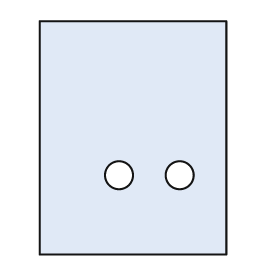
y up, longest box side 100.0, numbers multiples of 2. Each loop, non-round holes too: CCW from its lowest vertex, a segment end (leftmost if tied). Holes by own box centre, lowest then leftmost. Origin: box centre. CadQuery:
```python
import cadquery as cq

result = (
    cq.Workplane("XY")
    .moveTo(-40.0, -50.0)
    .lineTo(40.0, -50.0)
    .lineTo(40.0, 50.0)
    .lineTo(-40.0, 50.0)
    .close()
    .moveTo(-6.0, -16.0)
    .circle(6.0)
    .moveTo(20.0, -16.0)
    .circle(6.0)
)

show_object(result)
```